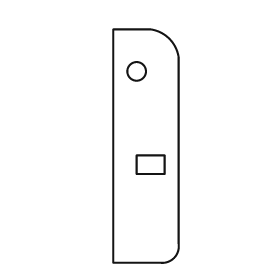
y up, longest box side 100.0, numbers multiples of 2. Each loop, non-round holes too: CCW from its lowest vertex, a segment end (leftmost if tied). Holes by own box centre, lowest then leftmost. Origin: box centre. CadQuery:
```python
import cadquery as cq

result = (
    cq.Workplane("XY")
    .moveTo(-14.0, -50.0)
    .lineTo(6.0, -50.0)
    .threePointArc((12.0, -48.0), (14.0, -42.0))
    .lineTo(14.0, 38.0)
    .threePointArc((10.0, 46.0), (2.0, 50.0))
    .lineTo(-14.0, 50.0)
    .close()
    .moveTo(-4.0, -12.0)
    .lineTo(8.0, -12.0)
    .lineTo(8.0, -4.0)
    .lineTo(-4.0, -4.0)
    .close()
    .moveTo(-4.0, 32.0)
    .circle(4.0)
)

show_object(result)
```